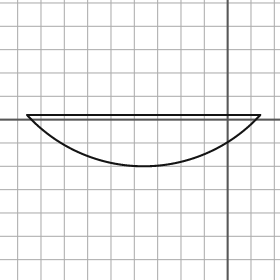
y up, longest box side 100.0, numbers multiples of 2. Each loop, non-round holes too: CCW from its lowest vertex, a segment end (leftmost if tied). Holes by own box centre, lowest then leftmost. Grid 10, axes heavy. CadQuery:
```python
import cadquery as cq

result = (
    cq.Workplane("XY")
    .moveTo(-86.0, 2.0)
    .threePointArc((-36.0, -20.0), (14.0, 2.0))
    .close()
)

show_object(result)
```